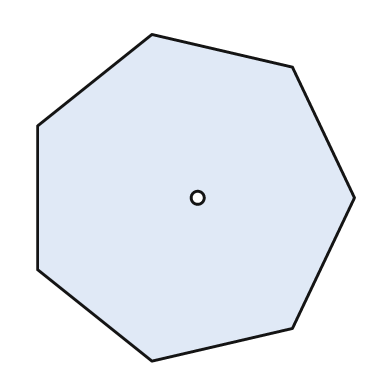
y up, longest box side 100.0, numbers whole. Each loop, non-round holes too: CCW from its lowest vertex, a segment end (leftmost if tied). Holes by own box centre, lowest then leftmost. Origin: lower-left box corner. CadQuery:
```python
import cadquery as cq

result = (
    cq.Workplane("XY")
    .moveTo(35.0, 0.0)
    .lineTo(78.0, 10.0)
    .lineTo(97.0, 50.0)
    .lineTo(78.0, 90.0)
    .lineTo(35.0, 100.0)
    .lineTo(0.0, 72.0)
    .lineTo(0.0, 28.0)
    .close()
    .moveTo(49.0, 50.0)
    .circle(2.0)
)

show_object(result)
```